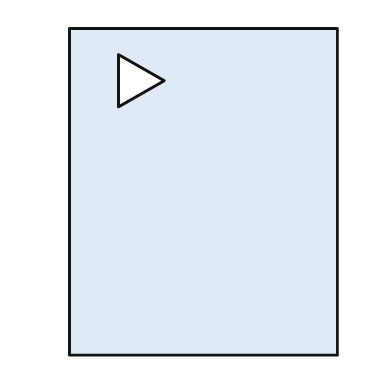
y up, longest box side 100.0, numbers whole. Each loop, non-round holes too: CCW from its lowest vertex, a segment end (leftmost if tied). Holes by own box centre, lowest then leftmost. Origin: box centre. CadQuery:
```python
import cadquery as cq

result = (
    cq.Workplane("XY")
    .moveTo(-41.0, -50.0)
    .lineTo(41.0, -50.0)
    .lineTo(41.0, 50.0)
    .lineTo(-41.0, 50.0)
    .close()
    .moveTo(-26.0, 26.0)
    .lineTo(-12.0, 34.0)
    .lineTo(-26.0, 42.0)
    .close()
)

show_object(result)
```